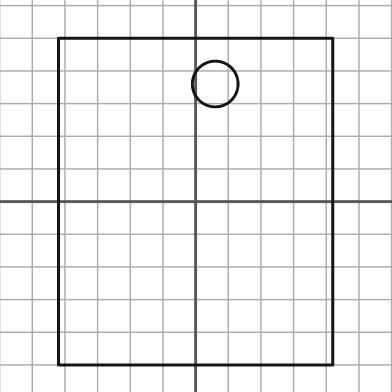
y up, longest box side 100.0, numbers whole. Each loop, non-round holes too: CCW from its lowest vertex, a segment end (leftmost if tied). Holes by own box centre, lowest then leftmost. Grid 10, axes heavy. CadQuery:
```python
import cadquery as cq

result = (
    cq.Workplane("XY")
    .moveTo(-42.0, -50.0)
    .lineTo(42.0, -50.0)
    .lineTo(42.0, 50.0)
    .lineTo(-42.0, 50.0)
    .close()
    .moveTo(6.0, 36.0)
    .circle(7.0)
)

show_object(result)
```